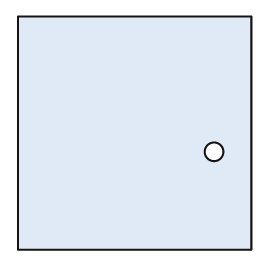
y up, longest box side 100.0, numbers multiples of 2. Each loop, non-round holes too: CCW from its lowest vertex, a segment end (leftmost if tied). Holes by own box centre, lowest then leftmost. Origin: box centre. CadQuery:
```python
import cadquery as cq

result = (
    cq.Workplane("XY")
    .moveTo(-50.0, -50.0)
    .lineTo(50.0, -50.0)
    .lineTo(50.0, 50.0)
    .lineTo(-50.0, 50.0)
    .close()
    .moveTo(34.0, -8.0)
    .circle(4.0)
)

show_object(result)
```